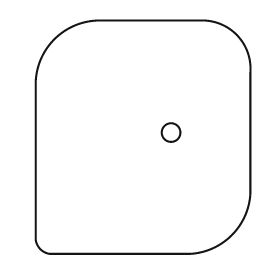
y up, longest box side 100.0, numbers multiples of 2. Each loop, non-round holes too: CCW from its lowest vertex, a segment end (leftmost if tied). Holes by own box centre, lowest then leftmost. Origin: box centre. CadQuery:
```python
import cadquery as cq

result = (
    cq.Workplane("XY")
    .moveTo(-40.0, -50.0)
    .lineTo(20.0, -50.0)
    .threePointArc((38.0, -42.0), (46.0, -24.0))
    .lineTo(46.0, 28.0)
    .threePointArc((40.0, 44.0), (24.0, 50.0))
    .lineTo(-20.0, 50.0)
    .threePointArc((-38.0, 42.0), (-46.0, 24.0))
    .lineTo(-46.0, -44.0)
    .threePointArc((-44.0, -48.0), (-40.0, -50.0))
    .close()
    .moveTo(12.0, 2.0)
    .circle(4.0)
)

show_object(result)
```